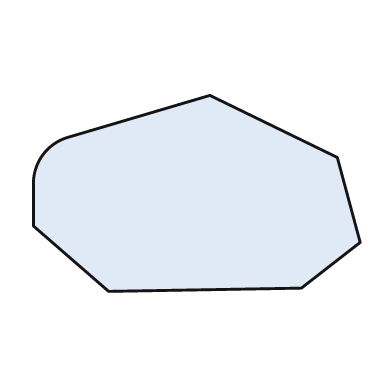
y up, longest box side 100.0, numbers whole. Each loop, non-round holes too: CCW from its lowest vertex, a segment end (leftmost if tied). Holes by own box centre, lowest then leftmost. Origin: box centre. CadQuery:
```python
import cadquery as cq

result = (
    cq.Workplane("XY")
    .moveTo(-27.0, -30.0)
    .lineTo(32.0, -29.0)
    .lineTo(50.0, -15.0)
    .lineTo(43.0, 11.0)
    .lineTo(4.0, 30.0)
    .lineTo(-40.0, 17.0)
    .threePointArc((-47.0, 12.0), (-50.0, 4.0))
    .lineTo(-50.0, -10.0)
    .close()
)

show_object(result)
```